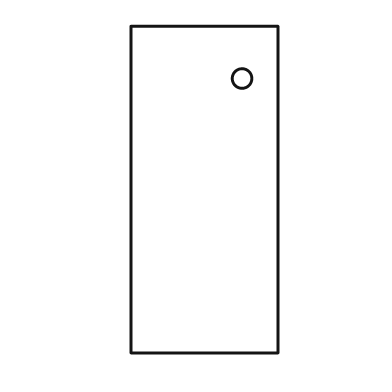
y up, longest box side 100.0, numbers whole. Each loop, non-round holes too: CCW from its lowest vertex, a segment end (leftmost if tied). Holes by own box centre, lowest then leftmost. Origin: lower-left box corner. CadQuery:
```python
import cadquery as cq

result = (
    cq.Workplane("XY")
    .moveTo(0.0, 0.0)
    .lineTo(45.0, 0.0)
    .lineTo(45.0, 100.0)
    .lineTo(0.0, 100.0)
    .close()
    .moveTo(34.0, 84.0)
    .circle(3.0)
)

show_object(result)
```